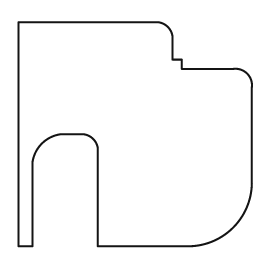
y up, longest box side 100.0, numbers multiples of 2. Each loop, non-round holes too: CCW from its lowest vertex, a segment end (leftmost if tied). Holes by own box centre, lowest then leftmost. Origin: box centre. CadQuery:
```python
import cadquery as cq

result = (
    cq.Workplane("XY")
    .moveTo(-50.0, -48.0)
    .lineTo(-44.0, -48.0)
    .lineTo(-44.0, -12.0)
    .threePointArc((-40.0, -4.0), (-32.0, 0.0))
    .lineTo(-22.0, 0.0)
    .threePointArc((-18.0, -2.0), (-16.0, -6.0))
    .lineTo(-16.0, -48.0)
    .lineTo(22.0, -48.0)
    .threePointArc((42.0, -40.0), (50.0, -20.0))
    .lineTo(50.0, 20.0)
    .threePointArc((48.0, 26.0), (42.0, 28.0))
    .lineTo(20.0, 28.0)
    .lineTo(20.0, 32.0)
    .lineTo(16.0, 32.0)
    .lineTo(16.0, 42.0)
    .threePointArc((14.0, 46.0), (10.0, 48.0))
    .lineTo(-50.0, 48.0)
    .close()
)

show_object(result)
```